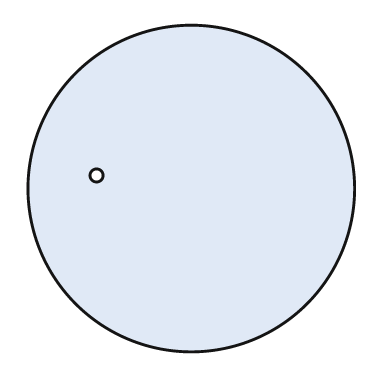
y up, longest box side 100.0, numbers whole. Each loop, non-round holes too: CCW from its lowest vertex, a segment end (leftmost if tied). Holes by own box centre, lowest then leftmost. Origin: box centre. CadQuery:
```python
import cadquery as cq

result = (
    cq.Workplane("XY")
    .moveTo(0.0, 0.0)
    .circle(50.0)
    .moveTo(-29.0, 4.0)
    .circle(2.0)
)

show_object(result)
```